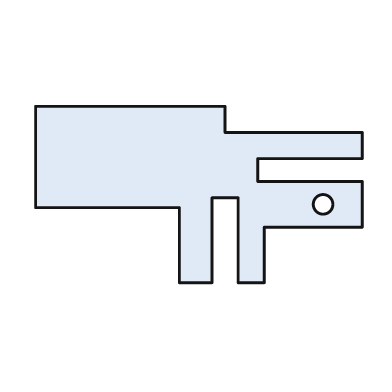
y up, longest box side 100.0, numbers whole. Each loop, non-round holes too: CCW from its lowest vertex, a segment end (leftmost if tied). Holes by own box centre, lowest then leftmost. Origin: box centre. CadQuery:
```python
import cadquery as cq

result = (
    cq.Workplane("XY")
    .moveTo(-6.0, -27.0)
    .lineTo(4.0, -27.0)
    .lineTo(4.0, -1.0)
    .lineTo(12.0, -1.0)
    .lineTo(12.0, -27.0)
    .lineTo(20.0, -27.0)
    .lineTo(20.0, -10.0)
    .lineTo(50.0, -10.0)
    .lineTo(50.0, 4.0)
    .lineTo(18.0, 4.0)
    .lineTo(18.0, 11.0)
    .lineTo(50.0, 11.0)
    .lineTo(50.0, 19.0)
    .lineTo(8.0, 19.0)
    .lineTo(8.0, 27.0)
    .lineTo(-50.0, 27.0)
    .lineTo(-50.0, -4.0)
    .lineTo(-6.0, -4.0)
    .close()
    .moveTo(38.0, -3.0)
    .circle(3.0)
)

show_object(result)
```